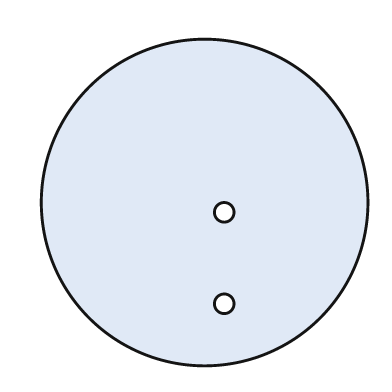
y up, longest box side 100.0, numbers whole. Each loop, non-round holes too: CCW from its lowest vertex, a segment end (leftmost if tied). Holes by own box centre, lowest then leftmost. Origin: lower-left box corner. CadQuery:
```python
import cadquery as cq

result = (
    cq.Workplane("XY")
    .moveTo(50.0, 50.0)
    .circle(50.0)
    .moveTo(56.0, 19.0)
    .circle(3.0)
    .moveTo(56.0, 47.0)
    .circle(3.0)
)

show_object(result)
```